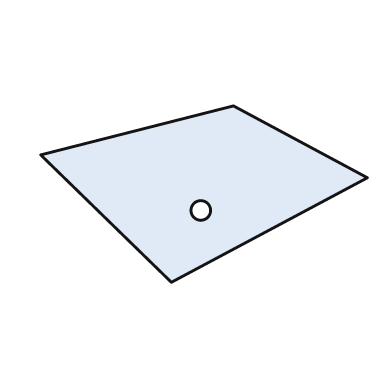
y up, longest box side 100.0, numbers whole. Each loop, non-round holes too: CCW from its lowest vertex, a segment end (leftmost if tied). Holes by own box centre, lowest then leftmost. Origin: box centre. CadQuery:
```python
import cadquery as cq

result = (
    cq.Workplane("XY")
    .moveTo(-10.0, -27.0)
    .lineTo(50.0, 5.0)
    .lineTo(9.0, 27.0)
    .lineTo(-50.0, 12.0)
    .close()
    .moveTo(-1.0, -5.0)
    .circle(3.0)
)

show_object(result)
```